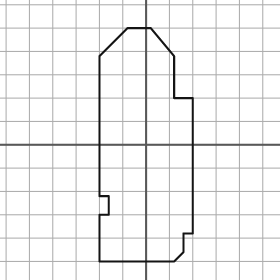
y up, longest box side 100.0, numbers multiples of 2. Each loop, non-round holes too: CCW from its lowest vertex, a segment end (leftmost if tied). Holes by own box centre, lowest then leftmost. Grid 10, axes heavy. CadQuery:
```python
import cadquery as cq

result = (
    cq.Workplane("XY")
    .moveTo(-20.0, -50.0)
    .lineTo(12.0, -50.0)
    .lineTo(16.0, -46.0)
    .lineTo(16.0, -38.0)
    .lineTo(20.0, -38.0)
    .lineTo(20.0, 20.0)
    .lineTo(12.0, 20.0)
    .lineTo(12.0, 38.0)
    .lineTo(2.0, 50.0)
    .lineTo(-8.0, 50.0)
    .lineTo(-20.0, 38.0)
    .lineTo(-20.0, -22.0)
    .lineTo(-16.0, -22.0)
    .lineTo(-16.0, -30.0)
    .lineTo(-20.0, -30.0)
    .close()
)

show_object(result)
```